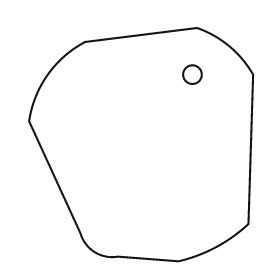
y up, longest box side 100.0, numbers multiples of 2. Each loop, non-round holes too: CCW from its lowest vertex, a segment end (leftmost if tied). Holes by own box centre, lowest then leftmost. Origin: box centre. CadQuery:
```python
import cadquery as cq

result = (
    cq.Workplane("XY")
    .moveTo(16.0, -50.0)
    .threePointArc((32.0, -44.0), (46.0, -34.0))
    .lineTo(48.0, 30.0)
    .threePointArc((38.0, 42.0), (24.0, 50.0))
    .lineTo(-24.0, 44.0)
    .threePointArc((-40.0, 30.0), (-48.0, 10.0))
    .lineTo(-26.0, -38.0)
    .threePointArc((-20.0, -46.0), (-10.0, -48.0))
    .close()
    .moveTo(22.0, 30.0)
    .circle(4.0)
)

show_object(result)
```